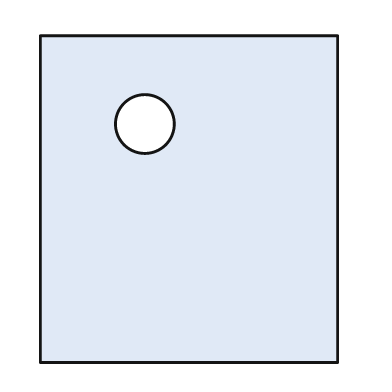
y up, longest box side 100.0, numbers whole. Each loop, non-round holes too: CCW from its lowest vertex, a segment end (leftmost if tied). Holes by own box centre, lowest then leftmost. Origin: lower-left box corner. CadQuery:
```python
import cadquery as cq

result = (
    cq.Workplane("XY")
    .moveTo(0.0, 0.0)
    .lineTo(91.0, 0.0)
    .lineTo(91.0, 100.0)
    .lineTo(0.0, 100.0)
    .close()
    .moveTo(32.0, 73.0)
    .circle(9.0)
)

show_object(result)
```